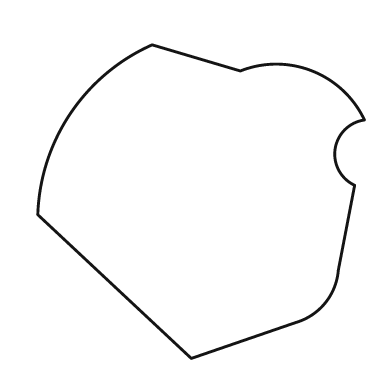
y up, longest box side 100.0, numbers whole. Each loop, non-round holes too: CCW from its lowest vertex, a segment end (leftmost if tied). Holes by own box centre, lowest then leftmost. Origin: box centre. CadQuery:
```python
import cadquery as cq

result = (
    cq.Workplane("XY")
    .moveTo(-3.0, -48.0)
    .lineTo(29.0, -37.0)
    .threePointArc((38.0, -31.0), (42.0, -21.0))
    .lineTo(47.0, 5.0)
    .threePointArc((41.0, 16.0), (50.0, 25.0))
    .threePointArc((34.0, 40.0), (12.0, 40.0))
    .lineTo(-15.0, 48.0)
    .threePointArc((-40.0, 27.0), (-50.0, -4.0))
    .close()
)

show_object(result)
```